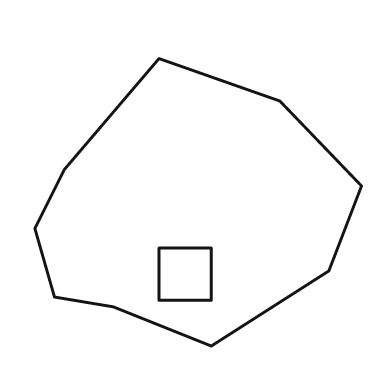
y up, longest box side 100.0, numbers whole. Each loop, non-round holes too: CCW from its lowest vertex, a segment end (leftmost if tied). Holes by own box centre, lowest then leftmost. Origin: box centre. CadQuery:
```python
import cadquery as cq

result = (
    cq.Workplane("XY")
    .moveTo(4.0, -44.0)
    .lineTo(40.0, -21.0)
    .lineTo(50.0, 5.0)
    .lineTo(25.0, 31.0)
    .lineTo(-12.0, 44.0)
    .lineTo(-41.0, 10.0)
    .lineTo(-50.0, -8.0)
    .lineTo(-44.0, -29.0)
    .lineTo(-26.0, -32.0)
    .close()
    .moveTo(-12.0, -30.0)
    .lineTo(4.0, -30.0)
    .lineTo(4.0, -14.0)
    .lineTo(-12.0, -14.0)
    .close()
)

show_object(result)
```